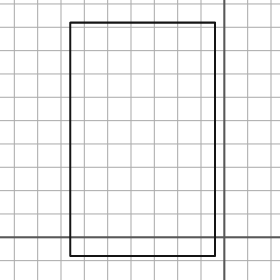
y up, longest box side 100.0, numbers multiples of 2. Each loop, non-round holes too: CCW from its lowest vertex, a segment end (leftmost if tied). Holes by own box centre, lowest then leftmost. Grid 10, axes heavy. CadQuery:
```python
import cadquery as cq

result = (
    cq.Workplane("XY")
    .moveTo(-66.0, -8.0)
    .lineTo(-4.0, -8.0)
    .lineTo(-4.0, 92.0)
    .lineTo(-66.0, 92.0)
    .close()
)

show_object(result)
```